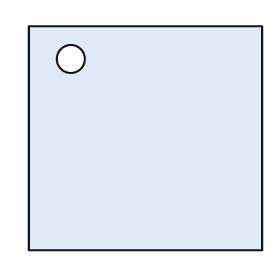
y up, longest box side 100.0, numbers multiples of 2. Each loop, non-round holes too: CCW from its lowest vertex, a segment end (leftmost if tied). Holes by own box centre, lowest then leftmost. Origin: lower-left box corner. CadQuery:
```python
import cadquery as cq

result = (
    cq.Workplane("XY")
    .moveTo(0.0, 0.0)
    .lineTo(100.0, 0.0)
    .lineTo(100.0, 96.0)
    .lineTo(0.0, 96.0)
    .close()
    .moveTo(18.0, 82.0)
    .circle(6.0)
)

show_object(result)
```